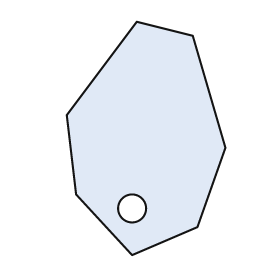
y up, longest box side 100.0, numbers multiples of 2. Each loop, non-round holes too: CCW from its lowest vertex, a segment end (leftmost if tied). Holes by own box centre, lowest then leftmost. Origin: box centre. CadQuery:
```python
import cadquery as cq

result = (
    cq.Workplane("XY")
    .moveTo(-6.0, -50.0)
    .lineTo(22.0, -38.0)
    .lineTo(34.0, -4.0)
    .lineTo(20.0, 44.0)
    .lineTo(-4.0, 50.0)
    .lineTo(-34.0, 10.0)
    .lineTo(-30.0, -24.0)
    .close()
    .moveTo(-6.0, -30.0)
    .circle(6.0)
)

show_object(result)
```